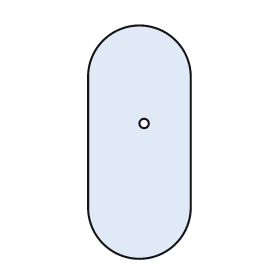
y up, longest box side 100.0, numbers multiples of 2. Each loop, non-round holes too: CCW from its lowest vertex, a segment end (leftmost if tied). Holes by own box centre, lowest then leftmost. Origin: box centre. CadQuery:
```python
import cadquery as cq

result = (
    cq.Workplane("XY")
    .moveTo(-22.0, -28.0)
    .threePointArc((0.0, -50.0), (22.0, -28.0))
    .lineTo(22.0, 28.0)
    .threePointArc((0.0, 50.0), (-22.0, 28.0))
    .close()
    .moveTo(2.0, 8.0)
    .circle(2.0)
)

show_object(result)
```